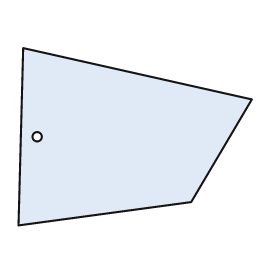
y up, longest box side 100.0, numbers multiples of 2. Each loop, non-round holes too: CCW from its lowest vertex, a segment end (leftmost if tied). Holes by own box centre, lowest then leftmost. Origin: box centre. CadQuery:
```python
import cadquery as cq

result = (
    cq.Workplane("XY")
    .moveTo(-50.0, -38.0)
    .lineTo(24.0, -28.0)
    .lineTo(50.0, 16.0)
    .lineTo(-48.0, 38.0)
    .close()
    .moveTo(-42.0, 0.0)
    .circle(2.0)
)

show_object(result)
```